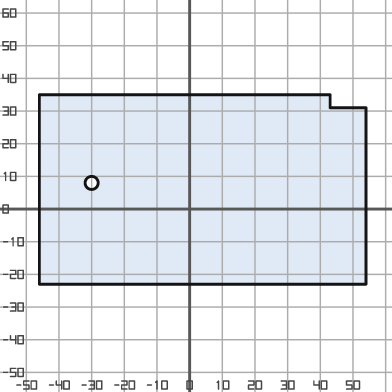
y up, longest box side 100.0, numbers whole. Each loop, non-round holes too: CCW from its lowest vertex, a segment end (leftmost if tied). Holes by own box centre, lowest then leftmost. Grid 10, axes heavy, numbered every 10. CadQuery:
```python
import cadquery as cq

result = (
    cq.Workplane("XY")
    .moveTo(-46.0, -23.0)
    .lineTo(54.0, -23.0)
    .lineTo(54.0, 31.0)
    .lineTo(43.0, 31.0)
    .lineTo(43.0, 35.0)
    .lineTo(-46.0, 35.0)
    .close()
    .moveTo(-30.0, 8.0)
    .circle(2.0)
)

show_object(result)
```